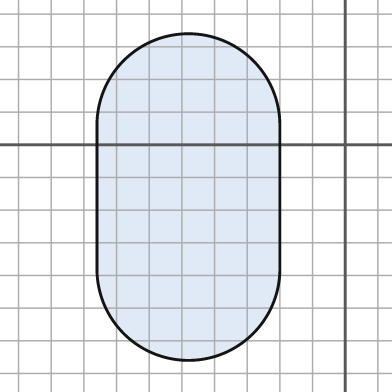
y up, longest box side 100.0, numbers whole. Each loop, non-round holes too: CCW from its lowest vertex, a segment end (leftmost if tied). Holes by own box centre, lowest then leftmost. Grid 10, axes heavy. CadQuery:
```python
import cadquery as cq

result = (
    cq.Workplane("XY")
    .moveTo(-76.0, -38.0)
    .threePointArc((-48.0, -66.0), (-20.0, -38.0))
    .lineTo(-20.0, 6.0)
    .threePointArc((-48.0, 34.0), (-76.0, 6.0))
    .close()
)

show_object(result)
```